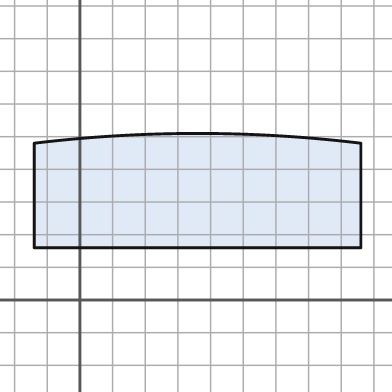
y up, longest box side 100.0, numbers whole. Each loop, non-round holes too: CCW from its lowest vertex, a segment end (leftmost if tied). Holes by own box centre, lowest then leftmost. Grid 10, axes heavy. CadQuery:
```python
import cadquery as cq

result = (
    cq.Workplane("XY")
    .moveTo(-14.0, 16.0)
    .lineTo(86.0, 16.0)
    .lineTo(86.0, 48.0)
    .threePointArc((36.0, 51.0), (-14.0, 48.0))
    .close()
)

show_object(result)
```